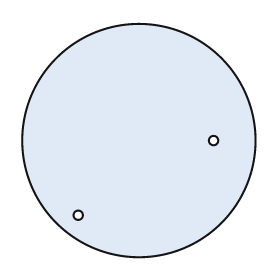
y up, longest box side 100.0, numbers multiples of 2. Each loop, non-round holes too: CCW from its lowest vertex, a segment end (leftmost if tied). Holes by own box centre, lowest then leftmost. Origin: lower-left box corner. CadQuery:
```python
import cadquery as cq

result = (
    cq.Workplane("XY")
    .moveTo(50.0, 50.0)
    .circle(50.0)
    .moveTo(24.0, 18.0)
    .circle(2.0)
    .moveTo(82.0, 50.0)
    .circle(2.0)
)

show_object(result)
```